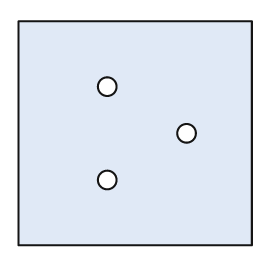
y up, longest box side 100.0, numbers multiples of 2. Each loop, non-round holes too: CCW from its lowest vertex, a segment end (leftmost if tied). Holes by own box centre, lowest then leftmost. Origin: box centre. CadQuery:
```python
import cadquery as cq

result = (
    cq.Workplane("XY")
    .moveTo(-50.0, -48.0)
    .lineTo(50.0, -48.0)
    .lineTo(50.0, 48.0)
    .lineTo(-50.0, 48.0)
    .close()
    .moveTo(-12.0, -20.0)
    .circle(4.0)
    .moveTo(22.0, 0.0)
    .circle(4.0)
    .moveTo(-12.0, 20.0)
    .circle(4.0)
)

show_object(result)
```